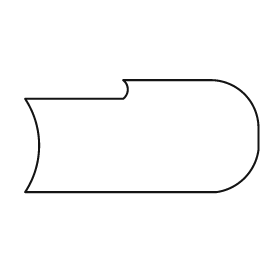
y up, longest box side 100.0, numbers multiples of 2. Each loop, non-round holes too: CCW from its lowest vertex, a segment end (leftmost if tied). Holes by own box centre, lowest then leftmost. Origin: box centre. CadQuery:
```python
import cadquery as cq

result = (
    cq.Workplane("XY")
    .moveTo(-50.0, -24.0)
    .lineTo(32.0, -24.0)
    .threePointArc((44.0, -18.0), (50.0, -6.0))
    .lineTo(50.0, 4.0)
    .threePointArc((44.0, 18.0), (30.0, 24.0))
    .lineTo(-8.0, 24.0)
    .threePointArc((-6.0, 20.0), (-8.0, 16.0))
    .lineTo(-50.0, 16.0)
    .threePointArc((-44.0, -4.0), (-50.0, -24.0))
    .close()
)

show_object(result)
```